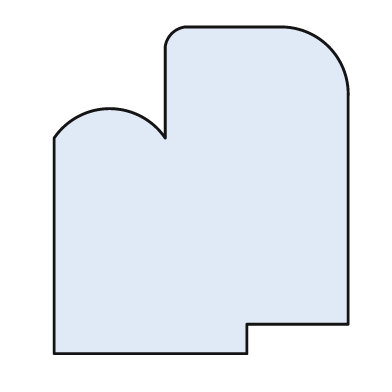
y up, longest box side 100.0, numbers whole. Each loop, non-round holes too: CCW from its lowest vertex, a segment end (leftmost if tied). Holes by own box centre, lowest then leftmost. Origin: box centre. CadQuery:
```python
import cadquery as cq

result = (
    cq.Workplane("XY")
    .moveTo(-45.0, -50.0)
    .lineTo(14.0, -50.0)
    .lineTo(14.0, -41.0)
    .lineTo(45.0, -41.0)
    .lineTo(45.0, 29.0)
    .threePointArc((39.0, 44.0), (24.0, 50.0))
    .lineTo(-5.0, 50.0)
    .threePointArc((-9.0, 48.0), (-11.0, 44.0))
    .lineTo(-11.0, 16.0)
    .threePointArc((-28.0, 25.0), (-45.0, 16.0))
    .close()
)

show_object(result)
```